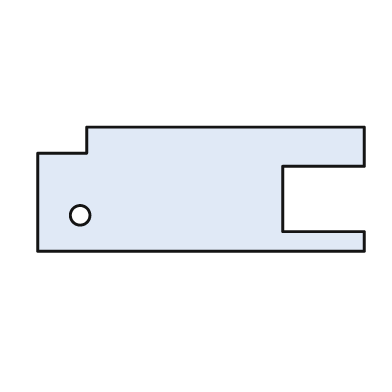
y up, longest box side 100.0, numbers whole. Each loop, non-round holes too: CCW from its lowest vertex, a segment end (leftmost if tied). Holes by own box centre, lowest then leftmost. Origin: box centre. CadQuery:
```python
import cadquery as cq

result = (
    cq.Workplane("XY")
    .moveTo(-50.0, -19.0)
    .lineTo(50.0, -19.0)
    .lineTo(50.0, -13.0)
    .lineTo(25.0, -13.0)
    .lineTo(25.0, 7.0)
    .lineTo(50.0, 7.0)
    .lineTo(50.0, 19.0)
    .lineTo(-35.0, 19.0)
    .lineTo(-35.0, 11.0)
    .lineTo(-50.0, 11.0)
    .close()
    .moveTo(-37.0, -8.0)
    .circle(3.0)
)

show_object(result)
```